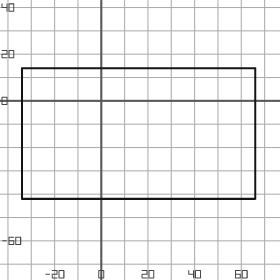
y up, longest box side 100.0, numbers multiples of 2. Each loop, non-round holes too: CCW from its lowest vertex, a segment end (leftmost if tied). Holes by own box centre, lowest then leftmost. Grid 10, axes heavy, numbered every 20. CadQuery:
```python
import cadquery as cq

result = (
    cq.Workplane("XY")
    .moveTo(-34.0, -42.0)
    .lineTo(66.0, -42.0)
    .lineTo(66.0, 14.0)
    .lineTo(-34.0, 14.0)
    .close()
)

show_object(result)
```